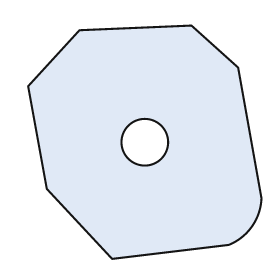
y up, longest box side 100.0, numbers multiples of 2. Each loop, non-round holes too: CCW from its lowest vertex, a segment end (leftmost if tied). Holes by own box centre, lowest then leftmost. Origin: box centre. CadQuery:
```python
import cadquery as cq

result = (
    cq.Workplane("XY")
    .moveTo(-14.0, -50.0)
    .lineTo(36.0, -44.0)
    .threePointArc((46.0, -36.0), (50.0, -24.0))
    .lineTo(40.0, 32.0)
    .lineTo(20.0, 50.0)
    .lineTo(-28.0, 48.0)
    .lineTo(-50.0, 24.0)
    .lineTo(-42.0, -20.0)
    .close()
    .moveTo(0.0, 0.0)
    .circle(10.0)
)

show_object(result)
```